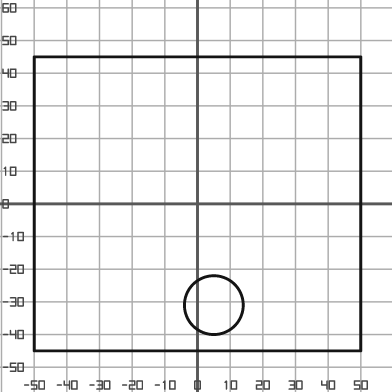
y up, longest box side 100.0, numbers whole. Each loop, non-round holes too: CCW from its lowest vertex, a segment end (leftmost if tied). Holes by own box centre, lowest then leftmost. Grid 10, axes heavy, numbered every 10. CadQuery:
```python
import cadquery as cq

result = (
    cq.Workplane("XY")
    .moveTo(-50.0, -45.0)
    .lineTo(50.0, -45.0)
    .lineTo(50.0, 45.0)
    .lineTo(-50.0, 45.0)
    .close()
    .moveTo(5.0, -31.0)
    .circle(9.0)
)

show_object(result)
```